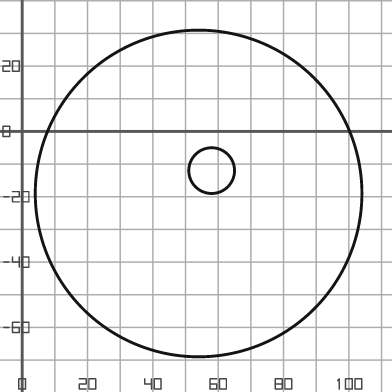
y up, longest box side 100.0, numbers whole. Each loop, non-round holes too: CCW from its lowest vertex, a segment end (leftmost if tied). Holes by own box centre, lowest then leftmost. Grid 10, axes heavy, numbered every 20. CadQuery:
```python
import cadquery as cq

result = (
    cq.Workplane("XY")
    .moveTo(54.0, -19.0)
    .circle(50.0)
    .moveTo(58.0, -12.0)
    .circle(7.0)
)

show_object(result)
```